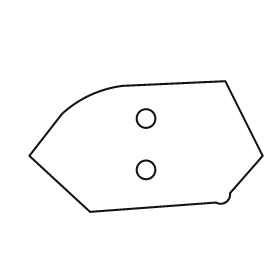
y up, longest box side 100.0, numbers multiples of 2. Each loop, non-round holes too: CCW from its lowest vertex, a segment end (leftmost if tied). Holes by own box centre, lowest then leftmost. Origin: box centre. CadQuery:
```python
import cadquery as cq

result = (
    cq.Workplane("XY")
    .moveTo(-24.0, -28.0)
    .lineTo(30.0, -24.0)
    .threePointArc((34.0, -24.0), (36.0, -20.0))
    .lineTo(50.0, -4.0)
    .lineTo(34.0, 28.0)
    .lineTo(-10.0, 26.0)
    .threePointArc((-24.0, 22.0), (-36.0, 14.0))
    .lineTo(-50.0, -4.0)
    .close()
    .moveTo(0.0, -10.0)
    .circle(4.0)
    .moveTo(0.0, 12.0)
    .circle(4.0)
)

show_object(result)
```